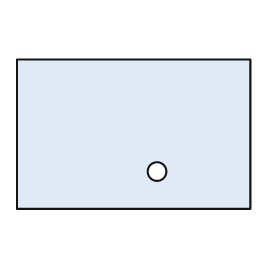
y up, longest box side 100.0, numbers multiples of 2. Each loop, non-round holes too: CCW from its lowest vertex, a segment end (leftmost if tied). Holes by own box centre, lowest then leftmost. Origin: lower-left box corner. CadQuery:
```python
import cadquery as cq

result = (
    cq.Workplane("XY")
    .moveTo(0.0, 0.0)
    .lineTo(100.0, 0.0)
    .lineTo(100.0, 64.0)
    .lineTo(0.0, 64.0)
    .close()
    .moveTo(60.0, 16.0)
    .circle(4.0)
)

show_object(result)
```